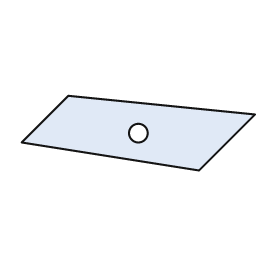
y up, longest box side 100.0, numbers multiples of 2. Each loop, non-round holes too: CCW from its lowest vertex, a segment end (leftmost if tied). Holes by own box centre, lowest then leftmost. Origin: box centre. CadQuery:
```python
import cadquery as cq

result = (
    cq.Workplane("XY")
    .moveTo(26.0, -16.0)
    .lineTo(50.0, 8.0)
    .lineTo(-30.0, 16.0)
    .lineTo(-50.0, -4.0)
    .close()
    .moveTo(0.0, 0.0)
    .circle(4.0)
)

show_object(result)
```